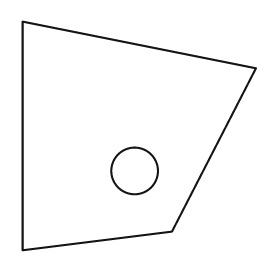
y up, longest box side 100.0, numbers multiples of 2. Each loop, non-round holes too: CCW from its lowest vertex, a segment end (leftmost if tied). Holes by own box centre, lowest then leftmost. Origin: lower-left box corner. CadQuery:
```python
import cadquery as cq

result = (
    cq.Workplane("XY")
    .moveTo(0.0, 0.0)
    .lineTo(64.0, 8.0)
    .lineTo(100.0, 78.0)
    .lineTo(0.0, 98.0)
    .close()
    .moveTo(48.0, 34.0)
    .circle(10.0)
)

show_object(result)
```